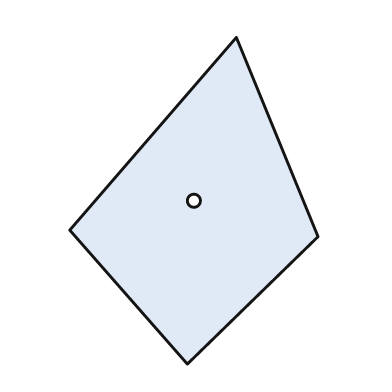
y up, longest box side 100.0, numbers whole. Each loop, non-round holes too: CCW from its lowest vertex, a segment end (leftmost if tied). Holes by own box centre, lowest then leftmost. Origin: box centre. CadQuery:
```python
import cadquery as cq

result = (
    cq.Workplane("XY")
    .moveTo(-2.0, -50.0)
    .lineTo(38.0, -11.0)
    .lineTo(13.0, 50.0)
    .lineTo(-38.0, -9.0)
    .close()
    .moveTo(0.0, 0.0)
    .circle(2.0)
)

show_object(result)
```